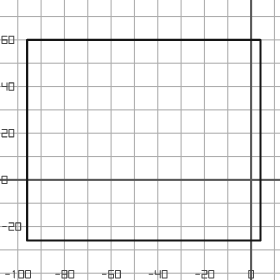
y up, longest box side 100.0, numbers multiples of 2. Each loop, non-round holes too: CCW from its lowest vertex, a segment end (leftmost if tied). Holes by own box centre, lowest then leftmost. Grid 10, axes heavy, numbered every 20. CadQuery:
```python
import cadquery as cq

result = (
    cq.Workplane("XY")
    .moveTo(-96.0, -26.0)
    .lineTo(4.0, -26.0)
    .lineTo(4.0, 60.0)
    .lineTo(-96.0, 60.0)
    .close()
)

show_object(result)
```